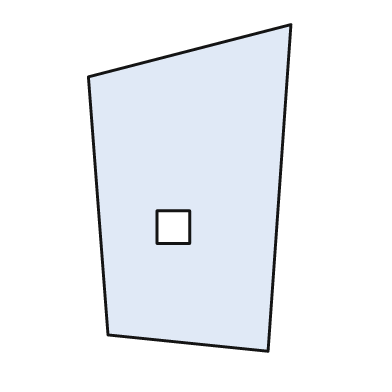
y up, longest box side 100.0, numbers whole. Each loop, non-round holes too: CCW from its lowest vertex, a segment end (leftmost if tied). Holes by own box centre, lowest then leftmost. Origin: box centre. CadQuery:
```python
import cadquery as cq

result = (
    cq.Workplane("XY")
    .moveTo(24.0, -50.0)
    .lineTo(31.0, 50.0)
    .lineTo(-31.0, 34.0)
    .lineTo(-25.0, -45.0)
    .close()
    .moveTo(-10.0, -17.0)
    .lineTo(0.0, -17.0)
    .lineTo(0.0, -7.0)
    .lineTo(-10.0, -7.0)
    .close()
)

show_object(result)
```